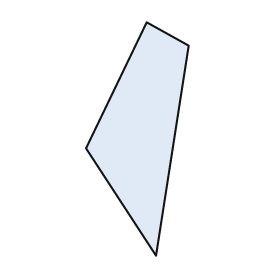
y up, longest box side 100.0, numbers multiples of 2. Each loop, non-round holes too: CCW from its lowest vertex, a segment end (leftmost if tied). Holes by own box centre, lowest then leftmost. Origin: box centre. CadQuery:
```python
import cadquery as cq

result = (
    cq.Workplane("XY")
    .moveTo(8.0, -50.0)
    .lineTo(22.0, 40.0)
    .lineTo(4.0, 50.0)
    .lineTo(-22.0, -4.0)
    .close()
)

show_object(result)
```